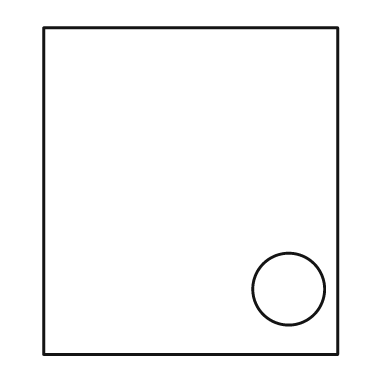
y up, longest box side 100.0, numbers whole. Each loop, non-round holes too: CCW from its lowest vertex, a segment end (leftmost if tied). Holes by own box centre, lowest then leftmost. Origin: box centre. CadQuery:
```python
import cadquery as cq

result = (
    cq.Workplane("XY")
    .moveTo(-45.0, -50.0)
    .lineTo(45.0, -50.0)
    .lineTo(45.0, 50.0)
    .lineTo(-45.0, 50.0)
    .close()
    .moveTo(30.0, -30.0)
    .circle(11.0)
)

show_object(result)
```